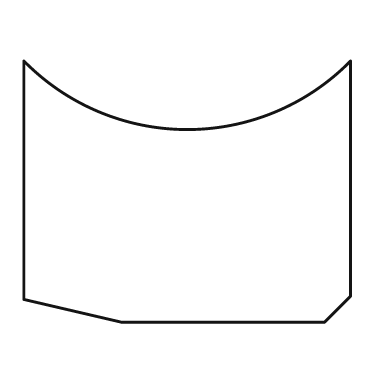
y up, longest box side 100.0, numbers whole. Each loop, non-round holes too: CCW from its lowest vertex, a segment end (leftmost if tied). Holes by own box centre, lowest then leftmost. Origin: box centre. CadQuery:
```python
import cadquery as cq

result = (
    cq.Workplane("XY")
    .moveTo(-20.0, -40.0)
    .lineTo(42.0, -40.0)
    .lineTo(50.0, -32.0)
    .lineTo(50.0, 40.0)
    .threePointArc((0.0, 19.0), (-50.0, 40.0))
    .lineTo(-50.0, -33.0)
    .close()
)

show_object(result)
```